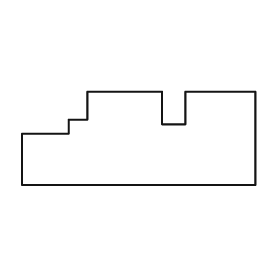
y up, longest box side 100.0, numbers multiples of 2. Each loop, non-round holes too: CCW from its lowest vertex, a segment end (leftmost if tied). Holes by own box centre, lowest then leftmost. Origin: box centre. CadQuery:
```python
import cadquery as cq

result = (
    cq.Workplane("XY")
    .moveTo(-50.0, -20.0)
    .lineTo(50.0, -20.0)
    .lineTo(50.0, 20.0)
    .lineTo(20.0, 20.0)
    .lineTo(20.0, 6.0)
    .lineTo(10.0, 6.0)
    .lineTo(10.0, 20.0)
    .lineTo(-22.0, 20.0)
    .lineTo(-22.0, 8.0)
    .lineTo(-30.0, 8.0)
    .lineTo(-30.0, 2.0)
    .lineTo(-50.0, 2.0)
    .close()
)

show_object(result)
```